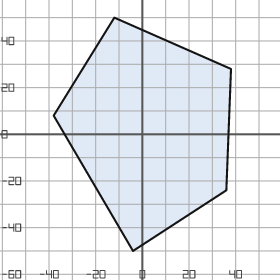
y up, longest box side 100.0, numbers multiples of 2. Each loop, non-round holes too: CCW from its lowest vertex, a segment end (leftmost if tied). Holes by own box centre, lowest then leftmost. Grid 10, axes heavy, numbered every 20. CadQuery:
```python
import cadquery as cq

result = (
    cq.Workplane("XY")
    .moveTo(-4.0, -50.0)
    .lineTo(36.0, -24.0)
    .lineTo(38.0, 28.0)
    .lineTo(-12.0, 50.0)
    .lineTo(-38.0, 8.0)
    .close()
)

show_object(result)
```